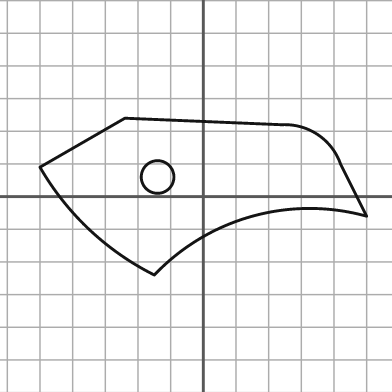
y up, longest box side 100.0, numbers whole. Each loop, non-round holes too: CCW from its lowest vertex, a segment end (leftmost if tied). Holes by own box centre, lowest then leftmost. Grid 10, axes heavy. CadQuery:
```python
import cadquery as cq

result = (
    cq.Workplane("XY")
    .moveTo(-15.0, -24.0)
    .threePointArc((15.0, -6.0), (50.0, -6.0))
    .lineTo(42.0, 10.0)
    .threePointArc((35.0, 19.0), (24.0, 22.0))
    .lineTo(-24.0, 24.0)
    .lineTo(-50.0, 9.0)
    .threePointArc((-35.0, -10.0), (-15.0, -24.0))
    .close()
    .moveTo(-14.0, 6.0)
    .circle(5.0)
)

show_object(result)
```